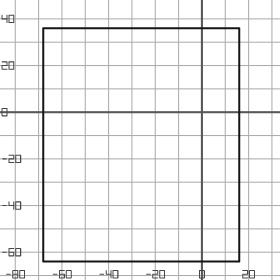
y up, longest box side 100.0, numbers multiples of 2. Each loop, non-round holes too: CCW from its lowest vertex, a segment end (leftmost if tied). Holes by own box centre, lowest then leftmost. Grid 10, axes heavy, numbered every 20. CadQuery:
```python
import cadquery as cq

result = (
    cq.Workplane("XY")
    .moveTo(-68.0, -64.0)
    .lineTo(16.0, -64.0)
    .lineTo(16.0, 36.0)
    .lineTo(-68.0, 36.0)
    .close()
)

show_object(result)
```